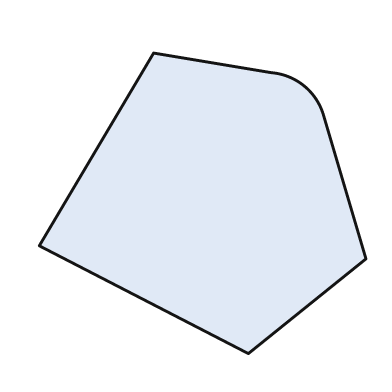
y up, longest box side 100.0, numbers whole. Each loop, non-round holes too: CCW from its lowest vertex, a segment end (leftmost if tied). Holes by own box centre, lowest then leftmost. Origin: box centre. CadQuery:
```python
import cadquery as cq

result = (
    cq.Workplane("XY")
    .moveTo(14.0, -46.0)
    .lineTo(50.0, -17.0)
    .lineTo(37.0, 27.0)
    .threePointArc((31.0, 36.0), (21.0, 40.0))
    .lineTo(-15.0, 46.0)
    .lineTo(-50.0, -13.0)
    .close()
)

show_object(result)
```